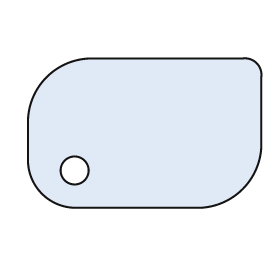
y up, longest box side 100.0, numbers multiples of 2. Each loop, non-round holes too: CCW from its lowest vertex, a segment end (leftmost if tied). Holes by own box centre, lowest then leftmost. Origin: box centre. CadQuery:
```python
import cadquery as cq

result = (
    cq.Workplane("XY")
    .moveTo(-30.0, -32.0)
    .lineTo(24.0, -32.0)
    .threePointArc((42.0, -24.0), (50.0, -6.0))
    .lineTo(50.0, 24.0)
    .threePointArc((48.0, 30.0), (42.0, 32.0))
    .lineTo(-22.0, 32.0)
    .threePointArc((-42.0, 24.0), (-50.0, 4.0))
    .lineTo(-50.0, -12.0)
    .threePointArc((-44.0, -26.0), (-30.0, -32.0))
    .close()
    .moveTo(-30.0, -16.0)
    .circle(6.0)
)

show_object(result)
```